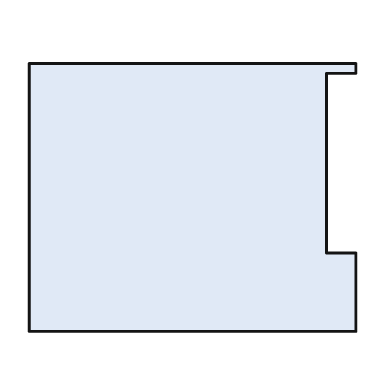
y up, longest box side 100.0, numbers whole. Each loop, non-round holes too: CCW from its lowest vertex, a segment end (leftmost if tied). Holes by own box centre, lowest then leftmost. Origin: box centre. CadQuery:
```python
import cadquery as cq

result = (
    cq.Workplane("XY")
    .moveTo(-50.0, -41.0)
    .lineTo(50.0, -41.0)
    .lineTo(50.0, -17.0)
    .lineTo(41.0, -17.0)
    .lineTo(41.0, 38.0)
    .lineTo(50.0, 38.0)
    .lineTo(50.0, 41.0)
    .lineTo(-50.0, 41.0)
    .close()
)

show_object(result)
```